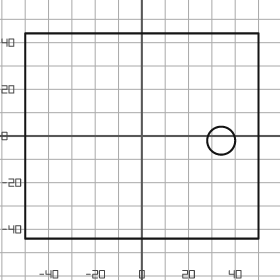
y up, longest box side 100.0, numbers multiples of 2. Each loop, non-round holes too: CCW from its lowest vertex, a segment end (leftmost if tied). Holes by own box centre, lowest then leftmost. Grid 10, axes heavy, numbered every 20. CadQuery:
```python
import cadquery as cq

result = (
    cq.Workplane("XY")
    .moveTo(-50.0, -44.0)
    .lineTo(50.0, -44.0)
    .lineTo(50.0, 44.0)
    .lineTo(-50.0, 44.0)
    .close()
    .moveTo(34.0, -2.0)
    .circle(6.0)
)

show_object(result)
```